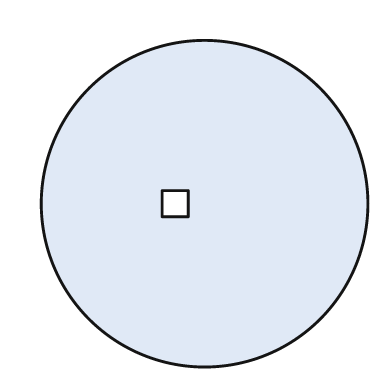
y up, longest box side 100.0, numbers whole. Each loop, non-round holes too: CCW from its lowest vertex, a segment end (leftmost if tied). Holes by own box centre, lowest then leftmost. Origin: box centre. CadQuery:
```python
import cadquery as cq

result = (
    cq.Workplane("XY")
    .moveTo(0.0, 0.0)
    .circle(50.0)
    .moveTo(-13.0, -4.0)
    .lineTo(-5.0, -4.0)
    .lineTo(-5.0, 4.0)
    .lineTo(-13.0, 4.0)
    .close()
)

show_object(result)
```